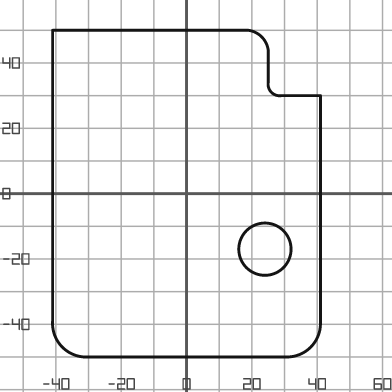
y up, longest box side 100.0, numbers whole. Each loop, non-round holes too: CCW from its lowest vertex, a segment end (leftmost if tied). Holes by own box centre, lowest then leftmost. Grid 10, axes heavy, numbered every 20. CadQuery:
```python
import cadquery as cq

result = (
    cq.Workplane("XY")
    .moveTo(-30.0, -50.0)
    .lineTo(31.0, -50.0)
    .threePointArc((38.0, -47.0), (41.0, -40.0))
    .lineTo(41.0, 30.0)
    .lineTo(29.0, 30.0)
    .threePointArc((26.0, 31.0), (25.0, 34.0))
    .lineTo(25.0, 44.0)
    .threePointArc((23.0, 48.0), (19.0, 50.0))
    .lineTo(-41.0, 50.0)
    .lineTo(-41.0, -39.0)
    .threePointArc((-38.0, -47.0), (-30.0, -50.0))
    .close()
    .moveTo(24.0, -17.0)
    .circle(8.0)
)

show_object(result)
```